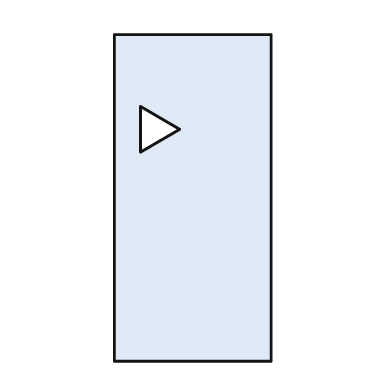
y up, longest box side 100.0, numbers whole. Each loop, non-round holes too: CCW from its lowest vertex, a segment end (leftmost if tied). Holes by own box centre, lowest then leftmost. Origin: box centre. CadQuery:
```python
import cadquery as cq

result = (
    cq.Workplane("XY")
    .moveTo(-24.0, -50.0)
    .lineTo(24.0, -50.0)
    .lineTo(24.0, 50.0)
    .lineTo(-24.0, 50.0)
    .close()
    .moveTo(-16.0, 14.0)
    .lineTo(-4.0, 21.0)
    .lineTo(-16.0, 28.0)
    .close()
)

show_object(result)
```